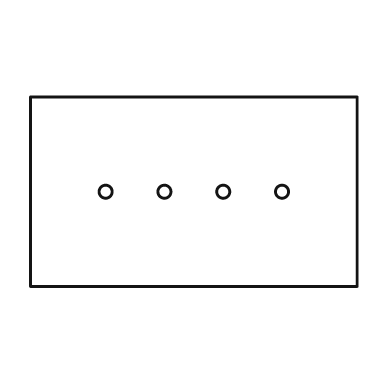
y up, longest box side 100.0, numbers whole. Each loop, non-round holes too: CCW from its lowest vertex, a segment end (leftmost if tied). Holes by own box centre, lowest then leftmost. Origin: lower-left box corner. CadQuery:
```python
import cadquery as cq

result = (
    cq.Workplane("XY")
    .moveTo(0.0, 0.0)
    .lineTo(100.0, 0.0)
    .lineTo(100.0, 58.0)
    .lineTo(0.0, 58.0)
    .close()
    .moveTo(23.0, 29.0)
    .circle(2.0)
    .moveTo(41.0, 29.0)
    .circle(2.0)
    .moveTo(59.0, 29.0)
    .circle(2.0)
    .moveTo(77.0, 29.0)
    .circle(2.0)
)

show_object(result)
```